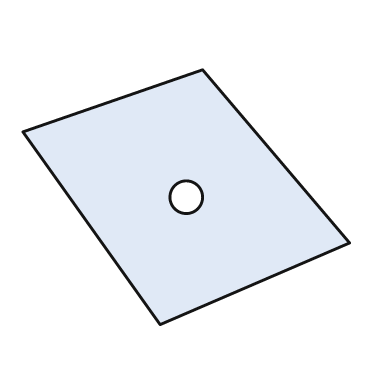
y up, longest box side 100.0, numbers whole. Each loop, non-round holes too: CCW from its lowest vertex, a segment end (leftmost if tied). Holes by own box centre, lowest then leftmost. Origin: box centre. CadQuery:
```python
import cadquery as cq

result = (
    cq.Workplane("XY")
    .moveTo(-8.0, -39.0)
    .lineTo(50.0, -14.0)
    .lineTo(5.0, 39.0)
    .lineTo(-50.0, 20.0)
    .close()
    .moveTo(0.0, 0.0)
    .circle(5.0)
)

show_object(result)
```